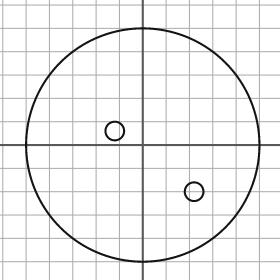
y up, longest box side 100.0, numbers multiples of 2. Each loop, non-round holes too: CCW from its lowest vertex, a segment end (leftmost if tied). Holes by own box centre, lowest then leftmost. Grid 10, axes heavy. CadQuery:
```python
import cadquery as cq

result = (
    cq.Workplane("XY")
    .moveTo(0.0, 0.0)
    .circle(50.0)
    .moveTo(22.0, -20.0)
    .circle(4.0)
    .moveTo(-12.0, 6.0)
    .circle(4.0)
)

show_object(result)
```